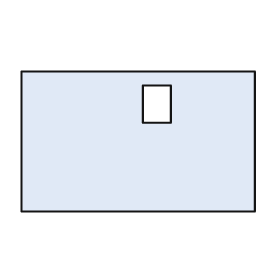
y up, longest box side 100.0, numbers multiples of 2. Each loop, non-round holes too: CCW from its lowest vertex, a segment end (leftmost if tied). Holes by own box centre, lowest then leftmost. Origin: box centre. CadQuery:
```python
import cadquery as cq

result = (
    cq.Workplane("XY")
    .moveTo(-50.0, -30.0)
    .lineTo(50.0, -30.0)
    .lineTo(50.0, 30.0)
    .lineTo(-50.0, 30.0)
    .close()
    .moveTo(2.0, 8.0)
    .lineTo(14.0, 8.0)
    .lineTo(14.0, 24.0)
    .lineTo(2.0, 24.0)
    .close()
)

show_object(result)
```